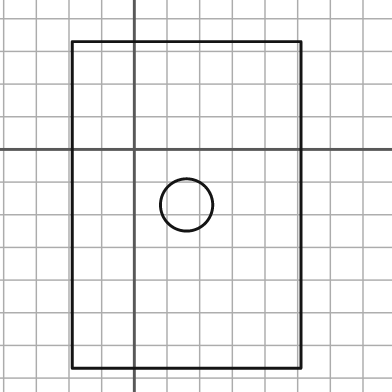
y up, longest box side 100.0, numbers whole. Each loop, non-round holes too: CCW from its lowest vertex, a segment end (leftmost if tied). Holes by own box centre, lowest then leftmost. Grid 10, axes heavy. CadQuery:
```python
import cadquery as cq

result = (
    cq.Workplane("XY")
    .moveTo(-19.0, -67.0)
    .lineTo(51.0, -67.0)
    .lineTo(51.0, 33.0)
    .lineTo(-19.0, 33.0)
    .close()
    .moveTo(16.0, -17.0)
    .circle(8.0)
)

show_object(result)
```